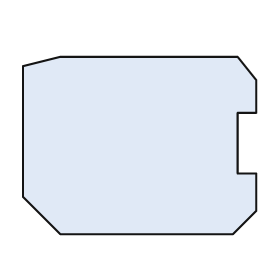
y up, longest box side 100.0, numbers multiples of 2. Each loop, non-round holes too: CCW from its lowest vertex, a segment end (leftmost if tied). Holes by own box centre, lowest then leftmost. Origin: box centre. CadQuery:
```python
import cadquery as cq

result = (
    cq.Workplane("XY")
    .moveTo(-34.0, -38.0)
    .lineTo(40.0, -38.0)
    .lineTo(50.0, -28.0)
    .lineTo(50.0, -12.0)
    .lineTo(42.0, -12.0)
    .lineTo(42.0, 14.0)
    .lineTo(50.0, 14.0)
    .lineTo(50.0, 28.0)
    .lineTo(42.0, 38.0)
    .lineTo(-34.0, 38.0)
    .lineTo(-50.0, 34.0)
    .lineTo(-50.0, -22.0)
    .close()
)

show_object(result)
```